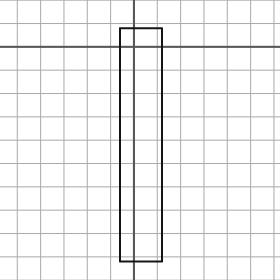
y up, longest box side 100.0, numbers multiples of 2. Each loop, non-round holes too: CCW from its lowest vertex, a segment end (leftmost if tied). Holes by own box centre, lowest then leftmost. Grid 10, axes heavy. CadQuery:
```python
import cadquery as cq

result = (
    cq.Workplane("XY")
    .moveTo(-6.0, -92.0)
    .lineTo(12.0, -92.0)
    .lineTo(12.0, 8.0)
    .lineTo(-6.0, 8.0)
    .close()
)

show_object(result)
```